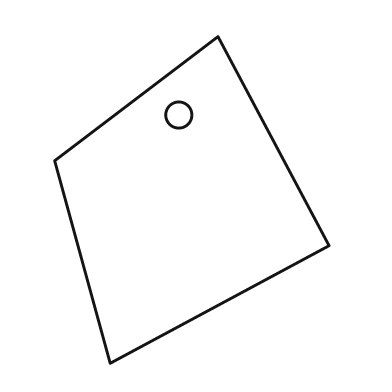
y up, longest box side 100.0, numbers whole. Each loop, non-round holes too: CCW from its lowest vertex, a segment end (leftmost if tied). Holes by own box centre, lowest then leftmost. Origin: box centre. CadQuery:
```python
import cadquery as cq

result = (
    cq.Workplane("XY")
    .moveTo(-25.0, -50.0)
    .lineTo(42.0, -14.0)
    .lineTo(8.0, 50.0)
    .lineTo(-42.0, 12.0)
    .close()
    .moveTo(-4.0, 26.0)
    .circle(4.0)
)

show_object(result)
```